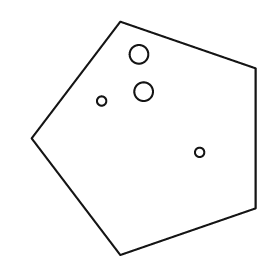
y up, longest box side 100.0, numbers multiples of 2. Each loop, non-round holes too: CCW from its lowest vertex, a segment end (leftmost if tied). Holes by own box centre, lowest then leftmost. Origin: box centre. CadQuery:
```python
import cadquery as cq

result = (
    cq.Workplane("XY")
    .moveTo(-10.0, -50.0)
    .lineTo(48.0, -30.0)
    .lineTo(48.0, 30.0)
    .lineTo(-10.0, 50.0)
    .lineTo(-48.0, 0.0)
    .close()
    .moveTo(24.0, -6.0)
    .circle(2.0)
    .moveTo(-18.0, 16.0)
    .circle(2.0)
    .moveTo(0.0, 20.0)
    .circle(4.0)
    .moveTo(-2.0, 36.0)
    .circle(4.0)
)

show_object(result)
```